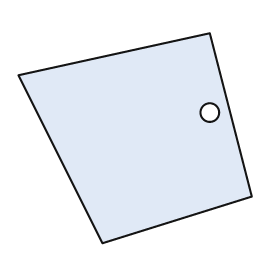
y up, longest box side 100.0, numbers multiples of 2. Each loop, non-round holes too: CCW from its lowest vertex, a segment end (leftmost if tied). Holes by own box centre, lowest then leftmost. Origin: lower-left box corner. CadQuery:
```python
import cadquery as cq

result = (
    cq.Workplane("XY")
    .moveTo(36.0, 0.0)
    .lineTo(100.0, 20.0)
    .lineTo(82.0, 90.0)
    .lineTo(0.0, 72.0)
    .close()
    .moveTo(82.0, 56.0)
    .circle(4.0)
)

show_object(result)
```